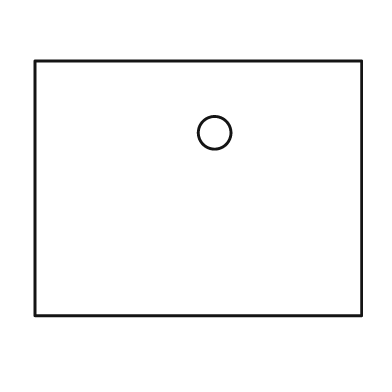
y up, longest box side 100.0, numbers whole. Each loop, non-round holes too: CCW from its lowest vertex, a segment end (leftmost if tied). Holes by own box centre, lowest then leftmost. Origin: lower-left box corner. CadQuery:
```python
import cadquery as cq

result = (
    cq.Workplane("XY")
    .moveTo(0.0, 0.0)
    .lineTo(100.0, 0.0)
    .lineTo(100.0, 78.0)
    .lineTo(0.0, 78.0)
    .close()
    .moveTo(55.0, 56.0)
    .circle(5.0)
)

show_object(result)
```